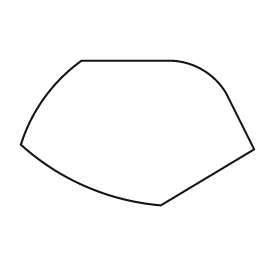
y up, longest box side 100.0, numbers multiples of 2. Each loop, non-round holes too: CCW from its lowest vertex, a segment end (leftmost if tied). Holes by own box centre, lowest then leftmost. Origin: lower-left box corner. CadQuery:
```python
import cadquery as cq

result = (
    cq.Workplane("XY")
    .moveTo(60.0, 0.0)
    .lineTo(100.0, 24.0)
    .lineTo(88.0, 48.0)
    .threePointArc((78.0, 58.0), (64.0, 62.0))
    .lineTo(26.0, 62.0)
    .threePointArc((10.0, 46.0), (0.0, 26.0))
    .threePointArc((28.0, 8.0), (60.0, 0.0))
    .close()
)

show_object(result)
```